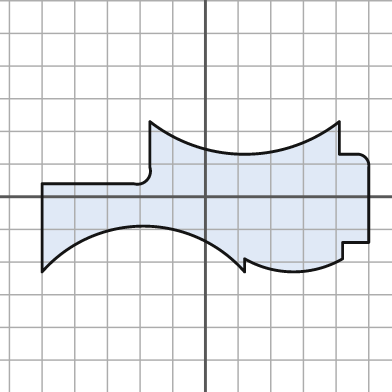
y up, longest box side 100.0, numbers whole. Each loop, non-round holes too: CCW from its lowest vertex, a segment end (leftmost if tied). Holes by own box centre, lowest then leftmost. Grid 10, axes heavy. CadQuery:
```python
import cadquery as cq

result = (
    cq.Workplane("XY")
    .moveTo(-50.0, -23.0)
    .threePointArc((-19.0, -9.0), (12.0, -23.0))
    .lineTo(12.0, -19.0)
    .threePointArc((27.0, -23.0), (42.0, -19.0))
    .lineTo(42.0, -14.0)
    .lineTo(50.0, -14.0)
    .lineTo(50.0, 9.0)
    .threePointArc((49.0, 12.0), (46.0, 13.0))
    .lineTo(41.0, 13.0)
    .lineTo(41.0, 23.0)
    .threePointArc((12.0, 13.0), (-17.0, 23.0))
    .lineTo(-17.0, 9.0)
    .threePointArc((-18.0, 5.0), (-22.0, 4.0))
    .lineTo(-50.0, 4.0)
    .close()
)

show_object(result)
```